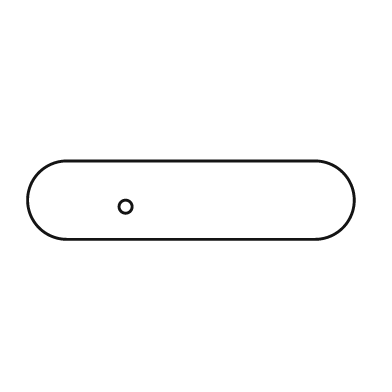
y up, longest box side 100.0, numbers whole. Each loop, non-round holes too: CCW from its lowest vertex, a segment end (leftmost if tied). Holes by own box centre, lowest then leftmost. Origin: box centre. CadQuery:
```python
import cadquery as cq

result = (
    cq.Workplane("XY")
    .moveTo(-38.0, -12.0)
    .lineTo(38.0, -12.0)
    .threePointArc((50.0, 0.0), (38.0, 12.0))
    .lineTo(-38.0, 12.0)
    .threePointArc((-50.0, 0.0), (-38.0, -12.0))
    .close()
    .moveTo(-20.0, -2.0)
    .circle(2.0)
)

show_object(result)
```